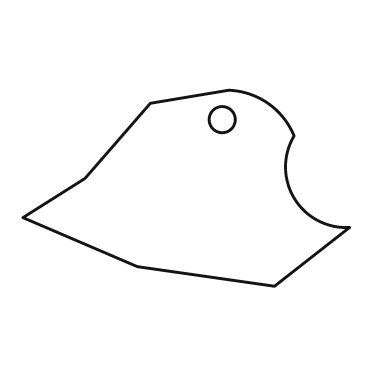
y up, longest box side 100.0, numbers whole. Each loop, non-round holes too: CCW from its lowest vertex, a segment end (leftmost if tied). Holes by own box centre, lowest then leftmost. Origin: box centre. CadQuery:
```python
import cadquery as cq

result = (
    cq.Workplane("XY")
    .moveTo(27.0, -30.0)
    .lineTo(50.0, -12.0)
    .threePointArc((33.0, -3.0), (33.0, 16.0))
    .threePointArc((25.0, 26.0), (13.0, 30.0))
    .lineTo(-11.0, 26.0)
    .lineTo(-31.0, 3.0)
    .lineTo(-50.0, -9.0)
    .lineTo(-15.0, -24.0)
    .close()
    .moveTo(11.0, 21.0)
    .circle(4.0)
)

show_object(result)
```